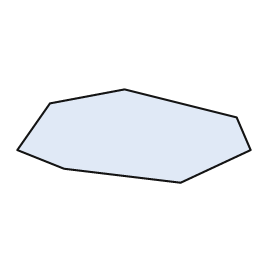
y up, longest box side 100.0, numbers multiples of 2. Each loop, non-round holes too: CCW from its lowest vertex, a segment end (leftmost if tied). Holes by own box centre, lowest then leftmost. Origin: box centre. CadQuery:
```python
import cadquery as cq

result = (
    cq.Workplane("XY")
    .moveTo(20.0, -20.0)
    .lineTo(50.0, -6.0)
    .lineTo(44.0, 8.0)
    .lineTo(-4.0, 20.0)
    .lineTo(-36.0, 14.0)
    .lineTo(-50.0, -6.0)
    .lineTo(-30.0, -14.0)
    .close()
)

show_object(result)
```